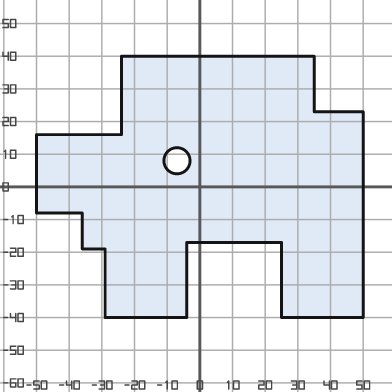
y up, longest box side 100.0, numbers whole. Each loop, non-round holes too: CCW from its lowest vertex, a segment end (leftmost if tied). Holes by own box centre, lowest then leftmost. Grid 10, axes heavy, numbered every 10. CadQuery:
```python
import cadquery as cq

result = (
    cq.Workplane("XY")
    .moveTo(-29.0, -40.0)
    .lineTo(-4.0, -40.0)
    .lineTo(-4.0, -17.0)
    .lineTo(25.0, -17.0)
    .lineTo(25.0, -40.0)
    .lineTo(50.0, -40.0)
    .lineTo(50.0, 23.0)
    .lineTo(35.0, 23.0)
    .lineTo(35.0, 40.0)
    .lineTo(-24.0, 40.0)
    .lineTo(-24.0, 16.0)
    .lineTo(-50.0, 16.0)
    .lineTo(-50.0, -8.0)
    .lineTo(-36.0, -8.0)
    .lineTo(-36.0, -19.0)
    .lineTo(-29.0, -19.0)
    .close()
    .moveTo(-7.0, 8.0)
    .circle(4.0)
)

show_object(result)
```